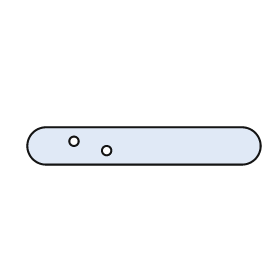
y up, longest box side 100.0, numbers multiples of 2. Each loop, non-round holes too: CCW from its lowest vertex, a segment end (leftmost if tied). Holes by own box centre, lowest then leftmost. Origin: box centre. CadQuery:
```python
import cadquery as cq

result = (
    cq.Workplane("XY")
    .moveTo(-42.0, -8.0)
    .lineTo(42.0, -8.0)
    .threePointArc((50.0, 0.0), (42.0, 8.0))
    .lineTo(-42.0, 8.0)
    .threePointArc((-50.0, 0.0), (-42.0, -8.0))
    .close()
    .moveTo(-16.0, -2.0)
    .circle(2.0)
    .moveTo(-30.0, 2.0)
    .circle(2.0)
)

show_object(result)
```